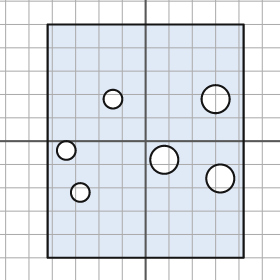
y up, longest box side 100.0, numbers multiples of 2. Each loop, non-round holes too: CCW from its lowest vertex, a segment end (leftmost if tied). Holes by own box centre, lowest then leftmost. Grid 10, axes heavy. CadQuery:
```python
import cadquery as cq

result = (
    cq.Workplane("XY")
    .moveTo(-42.0, -50.0)
    .lineTo(42.0, -50.0)
    .lineTo(42.0, 50.0)
    .lineTo(-42.0, 50.0)
    .close()
    .moveTo(-28.0, -22.0)
    .circle(4.0)
    .moveTo(32.0, -16.0)
    .circle(6.0)
    .moveTo(8.0, -8.0)
    .circle(6.0)
    .moveTo(-34.0, -4.0)
    .circle(4.0)
    .moveTo(-14.0, 18.0)
    .circle(4.0)
    .moveTo(30.0, 18.0)
    .circle(6.0)
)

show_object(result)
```